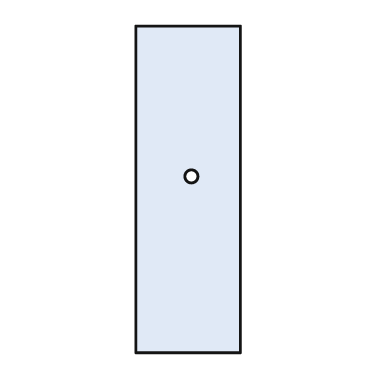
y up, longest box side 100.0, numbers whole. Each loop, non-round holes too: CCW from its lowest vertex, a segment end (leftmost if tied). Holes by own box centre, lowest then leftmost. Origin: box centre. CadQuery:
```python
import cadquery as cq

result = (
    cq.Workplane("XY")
    .moveTo(-16.0, -50.0)
    .lineTo(16.0, -50.0)
    .lineTo(16.0, 50.0)
    .lineTo(-16.0, 50.0)
    .close()
    .moveTo(1.0, 4.0)
    .circle(2.0)
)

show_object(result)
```